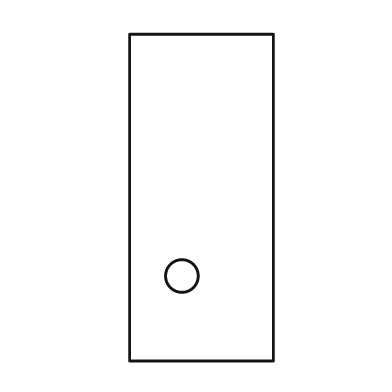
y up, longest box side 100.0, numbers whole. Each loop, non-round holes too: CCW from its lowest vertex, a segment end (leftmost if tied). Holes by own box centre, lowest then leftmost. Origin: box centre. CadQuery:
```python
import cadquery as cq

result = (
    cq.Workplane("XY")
    .moveTo(-22.0, -50.0)
    .lineTo(22.0, -50.0)
    .lineTo(22.0, 50.0)
    .lineTo(-22.0, 50.0)
    .close()
    .moveTo(-6.0, -24.0)
    .circle(5.0)
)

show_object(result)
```